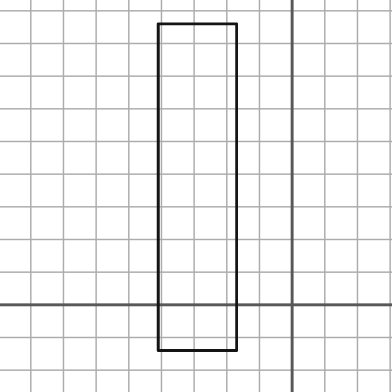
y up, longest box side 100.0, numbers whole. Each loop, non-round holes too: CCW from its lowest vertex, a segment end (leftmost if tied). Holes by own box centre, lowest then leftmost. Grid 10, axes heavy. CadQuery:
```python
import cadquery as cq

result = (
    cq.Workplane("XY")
    .moveTo(-41.0, -14.0)
    .lineTo(-17.0, -14.0)
    .lineTo(-17.0, 86.0)
    .lineTo(-41.0, 86.0)
    .close()
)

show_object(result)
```